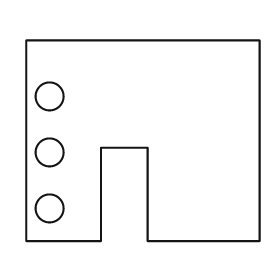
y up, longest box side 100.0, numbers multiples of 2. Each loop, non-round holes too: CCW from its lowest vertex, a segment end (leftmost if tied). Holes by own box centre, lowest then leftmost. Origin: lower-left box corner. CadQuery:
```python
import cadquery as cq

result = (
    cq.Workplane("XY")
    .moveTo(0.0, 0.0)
    .lineTo(32.0, 0.0)
    .lineTo(32.0, 40.0)
    .lineTo(52.0, 40.0)
    .lineTo(52.0, 0.0)
    .lineTo(100.0, 0.0)
    .lineTo(100.0, 86.0)
    .lineTo(0.0, 86.0)
    .close()
    .moveTo(10.0, 14.0)
    .circle(6.0)
    .moveTo(10.0, 38.0)
    .circle(6.0)
    .moveTo(10.0, 62.0)
    .circle(6.0)
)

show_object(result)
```